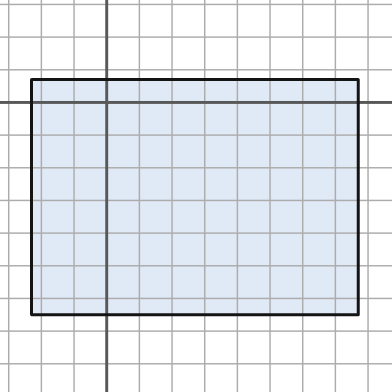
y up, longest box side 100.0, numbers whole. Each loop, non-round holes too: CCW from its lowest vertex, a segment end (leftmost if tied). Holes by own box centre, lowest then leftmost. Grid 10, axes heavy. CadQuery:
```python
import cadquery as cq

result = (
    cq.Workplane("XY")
    .moveTo(-23.0, -65.0)
    .lineTo(77.0, -65.0)
    .lineTo(77.0, 7.0)
    .lineTo(-23.0, 7.0)
    .close()
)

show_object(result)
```